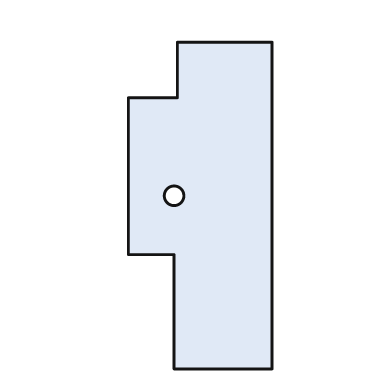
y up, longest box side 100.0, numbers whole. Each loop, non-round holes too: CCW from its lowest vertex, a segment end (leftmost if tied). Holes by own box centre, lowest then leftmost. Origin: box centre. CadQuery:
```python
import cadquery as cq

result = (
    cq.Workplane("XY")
    .moveTo(-8.0, -50.0)
    .lineTo(22.0, -50.0)
    .lineTo(22.0, 50.0)
    .lineTo(-7.0, 50.0)
    .lineTo(-7.0, 33.0)
    .lineTo(-22.0, 33.0)
    .lineTo(-22.0, -15.0)
    .lineTo(-8.0, -15.0)
    .close()
    .moveTo(-8.0, 3.0)
    .circle(3.0)
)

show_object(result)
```